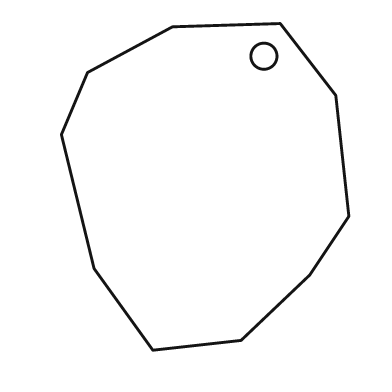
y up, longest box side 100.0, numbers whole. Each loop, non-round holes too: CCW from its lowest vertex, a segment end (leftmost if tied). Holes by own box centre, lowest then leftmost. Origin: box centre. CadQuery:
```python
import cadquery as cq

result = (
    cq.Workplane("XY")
    .moveTo(-16.0, -50.0)
    .lineTo(11.0, -47.0)
    .lineTo(32.0, -27.0)
    .lineTo(44.0, -9.0)
    .lineTo(40.0, 28.0)
    .lineTo(23.0, 50.0)
    .lineTo(-10.0, 49.0)
    .lineTo(-36.0, 35.0)
    .lineTo(-44.0, 16.0)
    .lineTo(-34.0, -25.0)
    .close()
    .moveTo(18.0, 40.0)
    .circle(4.0)
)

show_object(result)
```